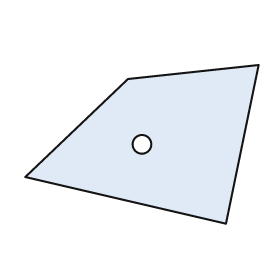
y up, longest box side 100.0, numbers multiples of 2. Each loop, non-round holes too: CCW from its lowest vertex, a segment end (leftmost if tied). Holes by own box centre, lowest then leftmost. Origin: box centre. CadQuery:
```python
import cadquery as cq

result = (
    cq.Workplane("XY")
    .moveTo(36.0, -34.0)
    .lineTo(50.0, 34.0)
    .lineTo(-6.0, 28.0)
    .lineTo(-50.0, -14.0)
    .close()
    .moveTo(0.0, 0.0)
    .circle(4.0)
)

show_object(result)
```